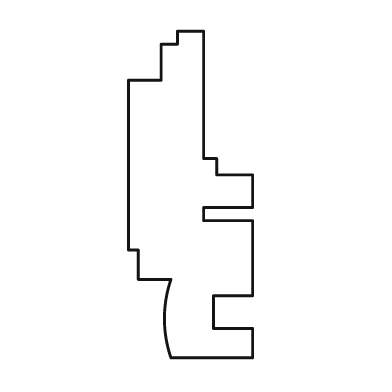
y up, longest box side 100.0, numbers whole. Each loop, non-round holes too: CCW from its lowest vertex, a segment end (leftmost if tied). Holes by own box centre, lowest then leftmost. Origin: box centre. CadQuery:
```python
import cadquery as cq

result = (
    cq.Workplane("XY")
    .moveTo(-6.0, -50.0)
    .lineTo(19.0, -50.0)
    .lineTo(19.0, -41.0)
    .lineTo(7.0, -41.0)
    .lineTo(7.0, -31.0)
    .lineTo(19.0, -31.0)
    .lineTo(19.0, -8.0)
    .lineTo(4.0, -8.0)
    .lineTo(4.0, -4.0)
    .lineTo(19.0, -4.0)
    .lineTo(19.0, 6.0)
    .lineTo(8.0, 6.0)
    .lineTo(8.0, 11.0)
    .lineTo(4.0, 11.0)
    .lineTo(4.0, 50.0)
    .lineTo(-4.0, 50.0)
    .lineTo(-4.0, 46.0)
    .lineTo(-9.0, 46.0)
    .lineTo(-9.0, 35.0)
    .lineTo(-19.0, 35.0)
    .lineTo(-19.0, -17.0)
    .lineTo(-16.0, -17.0)
    .lineTo(-16.0, -26.0)
    .lineTo(-6.0, -26.0)
    .threePointArc((-8.0, -38.0), (-6.0, -50.0))
    .close()
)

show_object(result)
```